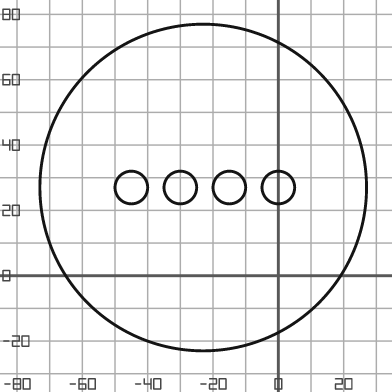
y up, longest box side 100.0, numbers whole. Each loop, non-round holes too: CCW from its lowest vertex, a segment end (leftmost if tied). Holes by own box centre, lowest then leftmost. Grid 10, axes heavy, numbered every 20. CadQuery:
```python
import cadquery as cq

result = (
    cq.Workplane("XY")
    .moveTo(-23.0, 27.0)
    .circle(50.0)
    .moveTo(-45.0, 27.0)
    .circle(5.0)
    .moveTo(-30.0, 27.0)
    .circle(5.0)
    .moveTo(-15.0, 27.0)
    .circle(5.0)
    .moveTo(0.0, 27.0)
    .circle(5.0)
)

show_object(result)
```